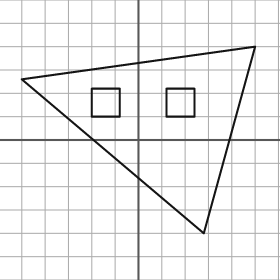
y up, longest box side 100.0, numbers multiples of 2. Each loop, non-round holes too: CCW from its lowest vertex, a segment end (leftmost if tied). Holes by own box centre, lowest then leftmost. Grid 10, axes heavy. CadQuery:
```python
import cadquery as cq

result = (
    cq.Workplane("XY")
    .moveTo(28.0, -40.0)
    .lineTo(50.0, 40.0)
    .lineTo(-50.0, 26.0)
    .close()
    .moveTo(-20.0, 10.0)
    .lineTo(-8.0, 10.0)
    .lineTo(-8.0, 22.0)
    .lineTo(-20.0, 22.0)
    .close()
    .moveTo(12.0, 10.0)
    .lineTo(24.0, 10.0)
    .lineTo(24.0, 22.0)
    .lineTo(12.0, 22.0)
    .close()
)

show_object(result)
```